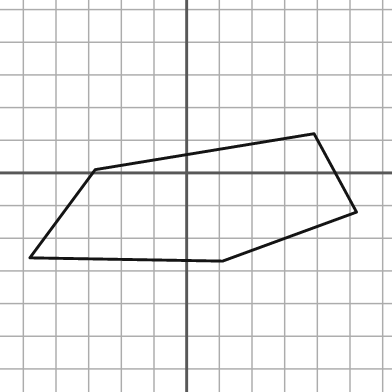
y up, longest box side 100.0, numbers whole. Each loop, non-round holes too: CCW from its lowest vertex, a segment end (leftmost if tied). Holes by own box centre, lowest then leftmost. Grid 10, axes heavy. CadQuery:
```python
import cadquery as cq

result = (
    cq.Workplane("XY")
    .moveTo(11.0, -27.0)
    .lineTo(52.0, -12.0)
    .lineTo(39.0, 12.0)
    .lineTo(-28.0, 1.0)
    .lineTo(-48.0, -26.0)
    .close()
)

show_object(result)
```